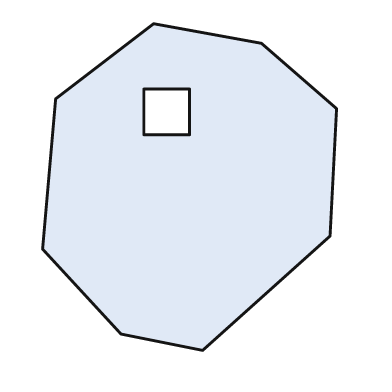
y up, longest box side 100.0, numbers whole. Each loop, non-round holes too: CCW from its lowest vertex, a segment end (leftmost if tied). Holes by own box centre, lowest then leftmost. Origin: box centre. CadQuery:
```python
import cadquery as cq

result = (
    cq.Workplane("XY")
    .moveTo(4.0, -50.0)
    .lineTo(43.0, -15.0)
    .lineTo(45.0, 24.0)
    .lineTo(22.0, 44.0)
    .lineTo(-11.0, 50.0)
    .lineTo(-41.0, 27.0)
    .lineTo(-45.0, -19.0)
    .lineTo(-21.0, -45.0)
    .close()
    .moveTo(-14.0, 16.0)
    .lineTo(0.0, 16.0)
    .lineTo(0.0, 30.0)
    .lineTo(-14.0, 30.0)
    .close()
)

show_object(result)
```